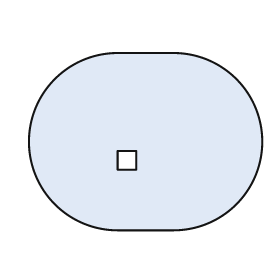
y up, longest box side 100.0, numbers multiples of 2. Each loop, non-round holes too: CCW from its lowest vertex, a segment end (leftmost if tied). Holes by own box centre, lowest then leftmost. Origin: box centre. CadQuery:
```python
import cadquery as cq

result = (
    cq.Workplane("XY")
    .moveTo(-12.0, -38.0)
    .lineTo(12.0, -38.0)
    .threePointArc((50.0, 0.0), (12.0, 38.0))
    .lineTo(-12.0, 38.0)
    .threePointArc((-50.0, 0.0), (-12.0, -38.0))
    .close()
    .moveTo(-12.0, -12.0)
    .lineTo(-4.0, -12.0)
    .lineTo(-4.0, -4.0)
    .lineTo(-12.0, -4.0)
    .close()
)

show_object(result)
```